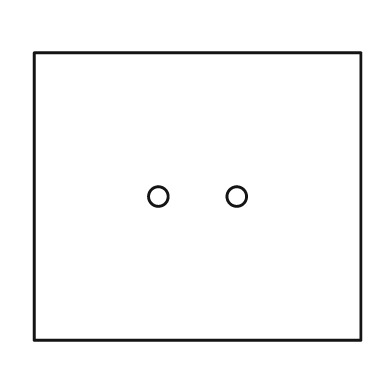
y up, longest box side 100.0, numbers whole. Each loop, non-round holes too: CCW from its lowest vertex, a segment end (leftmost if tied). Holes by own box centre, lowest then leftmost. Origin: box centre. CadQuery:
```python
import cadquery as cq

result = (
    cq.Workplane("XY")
    .moveTo(-50.0, -44.0)
    .lineTo(50.0, -44.0)
    .lineTo(50.0, 44.0)
    .lineTo(-50.0, 44.0)
    .close()
    .moveTo(-12.0, 0.0)
    .circle(3.0)
    .moveTo(12.0, 0.0)
    .circle(3.0)
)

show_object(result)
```